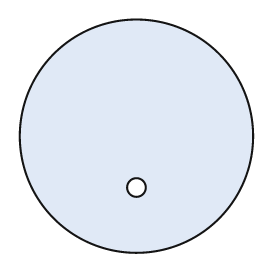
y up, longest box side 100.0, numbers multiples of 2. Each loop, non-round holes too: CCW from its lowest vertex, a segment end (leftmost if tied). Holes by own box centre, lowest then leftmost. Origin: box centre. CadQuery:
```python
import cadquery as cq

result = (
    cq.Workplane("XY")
    .moveTo(0.0, 0.0)
    .circle(50.0)
    .moveTo(0.0, -22.0)
    .circle(4.0)
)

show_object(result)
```